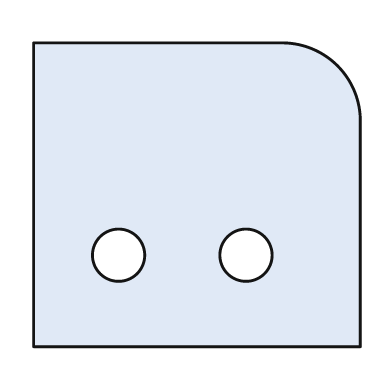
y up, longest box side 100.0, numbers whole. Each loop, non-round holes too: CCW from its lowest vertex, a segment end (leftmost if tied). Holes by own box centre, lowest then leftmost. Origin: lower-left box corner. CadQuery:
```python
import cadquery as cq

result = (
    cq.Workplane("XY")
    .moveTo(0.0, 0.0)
    .lineTo(100.0, 0.0)
    .lineTo(100.0, 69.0)
    .threePointArc((93.0, 86.0), (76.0, 93.0))
    .lineTo(0.0, 93.0)
    .close()
    .moveTo(26.0, 28.0)
    .circle(8.0)
    .moveTo(65.0, 28.0)
    .circle(8.0)
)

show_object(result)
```